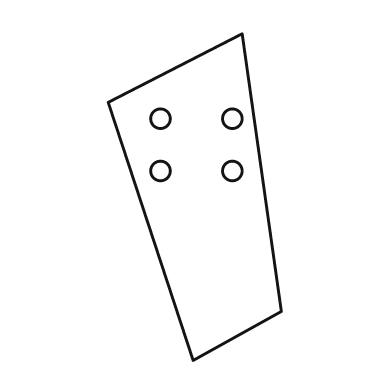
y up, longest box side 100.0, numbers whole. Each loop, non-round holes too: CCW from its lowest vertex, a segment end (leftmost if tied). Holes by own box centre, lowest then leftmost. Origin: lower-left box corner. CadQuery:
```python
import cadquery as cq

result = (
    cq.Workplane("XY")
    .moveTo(26.0, 0.0)
    .lineTo(53.0, 15.0)
    .lineTo(41.0, 100.0)
    .lineTo(0.0, 79.0)
    .close()
    .moveTo(16.0, 58.0)
    .circle(3.0)
    .moveTo(38.0, 58.0)
    .circle(3.0)
    .moveTo(16.0, 74.0)
    .circle(3.0)
    .moveTo(38.0, 74.0)
    .circle(3.0)
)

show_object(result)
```